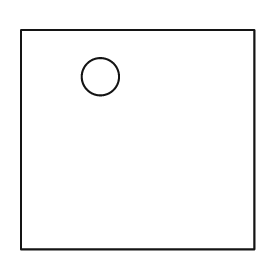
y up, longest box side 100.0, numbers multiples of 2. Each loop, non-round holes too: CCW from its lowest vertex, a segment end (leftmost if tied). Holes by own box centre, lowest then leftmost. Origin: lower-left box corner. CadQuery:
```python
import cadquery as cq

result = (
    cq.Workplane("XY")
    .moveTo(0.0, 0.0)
    .lineTo(100.0, 0.0)
    .lineTo(100.0, 94.0)
    .lineTo(0.0, 94.0)
    .close()
    .moveTo(34.0, 74.0)
    .circle(8.0)
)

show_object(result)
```